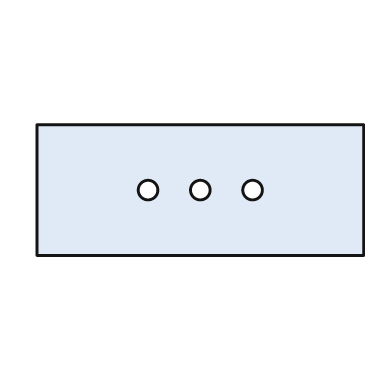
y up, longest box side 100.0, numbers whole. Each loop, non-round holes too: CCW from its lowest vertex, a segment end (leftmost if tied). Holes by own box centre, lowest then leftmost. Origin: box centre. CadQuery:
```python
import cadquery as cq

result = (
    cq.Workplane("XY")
    .moveTo(-50.0, -20.0)
    .lineTo(50.0, -20.0)
    .lineTo(50.0, 20.0)
    .lineTo(-50.0, 20.0)
    .close()
    .moveTo(-16.0, 0.0)
    .circle(3.0)
    .moveTo(0.0, 0.0)
    .circle(3.0)
    .moveTo(16.0, 0.0)
    .circle(3.0)
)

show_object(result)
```